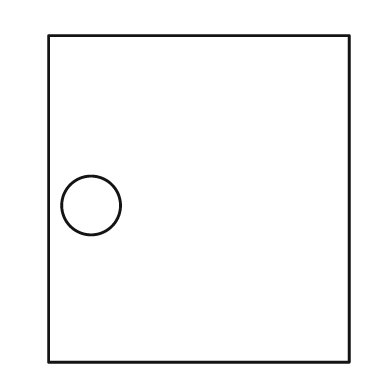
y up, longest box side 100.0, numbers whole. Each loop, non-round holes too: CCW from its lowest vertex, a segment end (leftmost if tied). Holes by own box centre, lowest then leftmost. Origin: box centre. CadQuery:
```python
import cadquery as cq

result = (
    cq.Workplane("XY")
    .moveTo(-46.0, -50.0)
    .lineTo(46.0, -50.0)
    .lineTo(46.0, 50.0)
    .lineTo(-46.0, 50.0)
    .close()
    .moveTo(-33.0, -2.0)
    .circle(9.0)
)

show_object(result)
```